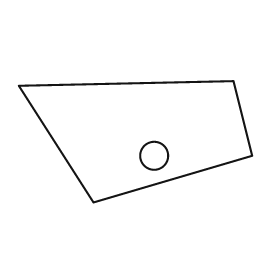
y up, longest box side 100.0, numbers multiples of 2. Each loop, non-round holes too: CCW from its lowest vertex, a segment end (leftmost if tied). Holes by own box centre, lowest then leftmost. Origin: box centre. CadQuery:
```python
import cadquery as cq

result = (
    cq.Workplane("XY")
    .moveTo(-18.0, -26.0)
    .lineTo(50.0, -6.0)
    .lineTo(42.0, 26.0)
    .lineTo(-50.0, 24.0)
    .close()
    .moveTo(8.0, -6.0)
    .circle(6.0)
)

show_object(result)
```